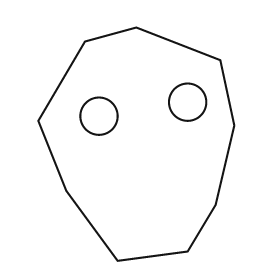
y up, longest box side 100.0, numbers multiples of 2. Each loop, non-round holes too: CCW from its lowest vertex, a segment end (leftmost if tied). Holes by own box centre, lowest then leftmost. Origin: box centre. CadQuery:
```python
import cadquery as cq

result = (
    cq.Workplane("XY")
    .moveTo(-8.0, -50.0)
    .lineTo(22.0, -46.0)
    .lineTo(34.0, -26.0)
    .lineTo(42.0, 8.0)
    .lineTo(36.0, 36.0)
    .lineTo(0.0, 50.0)
    .lineTo(-22.0, 44.0)
    .lineTo(-42.0, 10.0)
    .lineTo(-30.0, -20.0)
    .close()
    .moveTo(-16.0, 12.0)
    .circle(8.0)
    .moveTo(22.0, 18.0)
    .circle(8.0)
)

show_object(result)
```